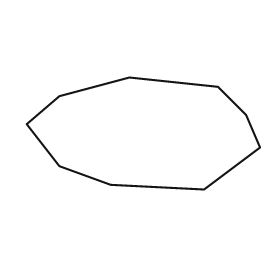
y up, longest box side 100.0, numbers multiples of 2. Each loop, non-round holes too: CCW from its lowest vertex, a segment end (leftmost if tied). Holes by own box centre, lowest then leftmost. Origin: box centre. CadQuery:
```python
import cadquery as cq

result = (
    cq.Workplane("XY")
    .moveTo(26.0, -24.0)
    .lineTo(50.0, -6.0)
    .lineTo(44.0, 8.0)
    .lineTo(32.0, 20.0)
    .lineTo(-6.0, 24.0)
    .lineTo(-36.0, 16.0)
    .lineTo(-50.0, 4.0)
    .lineTo(-36.0, -14.0)
    .lineTo(-14.0, -22.0)
    .close()
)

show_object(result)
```